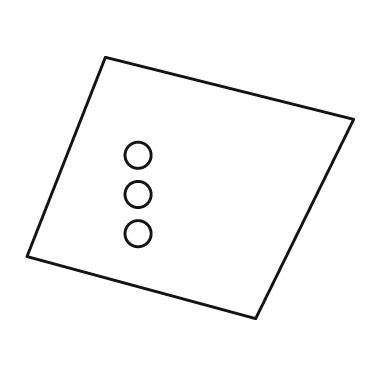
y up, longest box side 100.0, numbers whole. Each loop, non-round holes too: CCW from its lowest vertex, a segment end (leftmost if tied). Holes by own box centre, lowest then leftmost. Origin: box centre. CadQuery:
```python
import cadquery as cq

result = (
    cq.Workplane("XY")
    .moveTo(20.0, -40.0)
    .lineTo(50.0, 21.0)
    .lineTo(-26.0, 40.0)
    .lineTo(-50.0, -21.0)
    .close()
    .moveTo(-16.0, -14.0)
    .circle(4.0)
    .moveTo(-16.0, -2.0)
    .circle(4.0)
    .moveTo(-16.0, 10.0)
    .circle(4.0)
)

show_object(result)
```